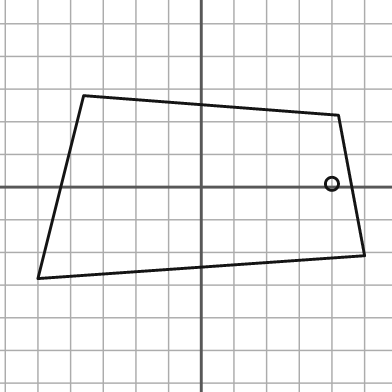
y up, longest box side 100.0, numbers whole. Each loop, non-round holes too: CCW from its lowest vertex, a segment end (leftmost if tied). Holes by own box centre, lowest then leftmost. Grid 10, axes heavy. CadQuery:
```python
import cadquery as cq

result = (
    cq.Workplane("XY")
    .moveTo(-50.0, -28.0)
    .lineTo(50.0, -21.0)
    .lineTo(42.0, 22.0)
    .lineTo(-36.0, 28.0)
    .close()
    .moveTo(40.0, 1.0)
    .circle(2.0)
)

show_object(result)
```